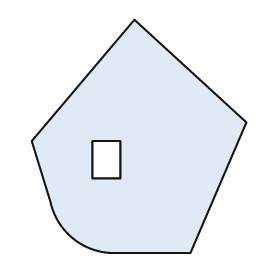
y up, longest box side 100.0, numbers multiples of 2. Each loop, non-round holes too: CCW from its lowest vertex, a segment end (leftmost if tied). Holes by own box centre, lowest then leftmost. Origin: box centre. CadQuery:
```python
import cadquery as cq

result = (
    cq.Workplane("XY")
    .moveTo(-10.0, -50.0)
    .lineTo(22.0, -50.0)
    .lineTo(46.0, 6.0)
    .lineTo(-2.0, 50.0)
    .lineTo(-46.0, -2.0)
    .lineTo(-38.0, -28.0)
    .threePointArc((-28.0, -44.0), (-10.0, -50.0))
    .close()
    .moveTo(-20.0, -18.0)
    .lineTo(-8.0, -18.0)
    .lineTo(-8.0, -2.0)
    .lineTo(-20.0, -2.0)
    .close()
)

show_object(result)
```